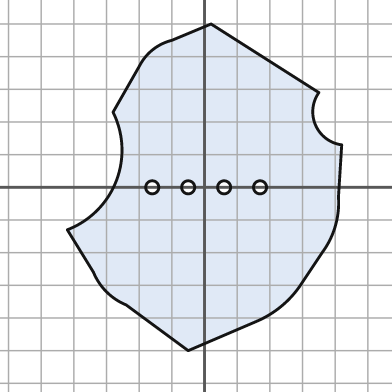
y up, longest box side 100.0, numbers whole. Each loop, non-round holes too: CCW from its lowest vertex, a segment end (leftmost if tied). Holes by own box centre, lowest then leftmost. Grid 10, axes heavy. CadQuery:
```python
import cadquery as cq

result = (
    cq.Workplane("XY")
    .moveTo(-5.0, -50.0)
    .lineTo(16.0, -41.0)
    .threePointArc((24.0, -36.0), (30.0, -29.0))
    .lineTo(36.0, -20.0)
    .threePointArc((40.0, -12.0), (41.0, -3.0))
    .lineTo(42.0, 13.0)
    .threePointArc((34.0, 19.0), (35.0, 29.0))
    .lineTo(2.0, 50.0)
    .lineTo(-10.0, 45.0)
    .threePointArc((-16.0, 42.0), (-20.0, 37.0))
    .lineTo(-28.0, 23.0)
    .threePointArc((-27.0, 2.0), (-42.0, -13.0))
    .lineTo(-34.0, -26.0)
    .threePointArc((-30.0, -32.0), (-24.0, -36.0))
    .close()
    .moveTo(-16.0, 0.0)
    .circle(2.0)
    .moveTo(-5.0, 0.0)
    .circle(2.0)
    .moveTo(6.0, 0.0)
    .circle(2.0)
    .moveTo(17.0, 0.0)
    .circle(2.0)
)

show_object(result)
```